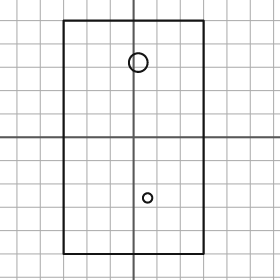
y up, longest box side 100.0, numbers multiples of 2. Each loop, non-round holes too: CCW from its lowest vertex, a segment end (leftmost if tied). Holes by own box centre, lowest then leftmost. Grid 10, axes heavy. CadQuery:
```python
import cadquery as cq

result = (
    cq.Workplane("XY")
    .moveTo(-30.0, -50.0)
    .lineTo(30.0, -50.0)
    .lineTo(30.0, 50.0)
    .lineTo(-30.0, 50.0)
    .close()
    .moveTo(6.0, -26.0)
    .circle(2.0)
    .moveTo(2.0, 32.0)
    .circle(4.0)
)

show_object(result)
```